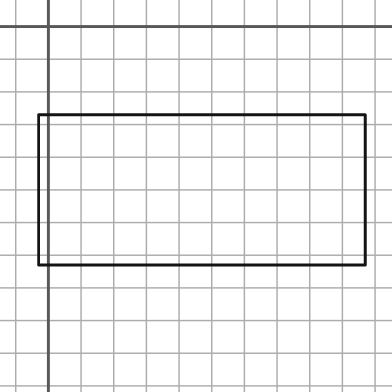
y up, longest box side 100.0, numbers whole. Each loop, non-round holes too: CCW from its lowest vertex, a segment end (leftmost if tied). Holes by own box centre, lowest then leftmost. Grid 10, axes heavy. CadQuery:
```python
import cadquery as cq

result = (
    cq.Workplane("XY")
    .moveTo(-3.0, -73.0)
    .lineTo(97.0, -73.0)
    .lineTo(97.0, -27.0)
    .lineTo(-3.0, -27.0)
    .close()
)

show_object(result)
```